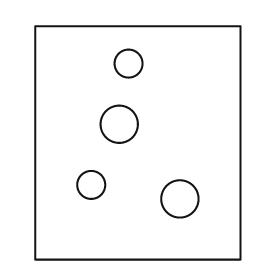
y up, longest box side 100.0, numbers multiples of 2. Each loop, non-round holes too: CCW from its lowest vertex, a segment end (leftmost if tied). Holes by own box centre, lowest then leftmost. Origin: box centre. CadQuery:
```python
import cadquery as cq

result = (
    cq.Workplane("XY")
    .moveTo(-44.0, -50.0)
    .lineTo(44.0, -50.0)
    .lineTo(44.0, 50.0)
    .lineTo(-44.0, 50.0)
    .close()
    .moveTo(18.0, -24.0)
    .circle(8.0)
    .moveTo(-20.0, -18.0)
    .circle(6.0)
    .moveTo(-8.0, 8.0)
    .circle(8.0)
    .moveTo(-4.0, 34.0)
    .circle(6.0)
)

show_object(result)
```